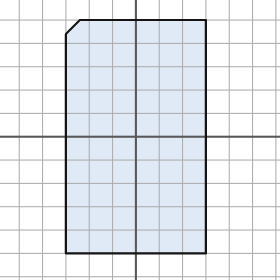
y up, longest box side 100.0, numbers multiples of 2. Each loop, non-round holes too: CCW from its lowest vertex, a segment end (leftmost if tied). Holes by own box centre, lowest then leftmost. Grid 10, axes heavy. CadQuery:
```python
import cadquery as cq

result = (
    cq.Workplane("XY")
    .moveTo(-30.0, -50.0)
    .lineTo(30.0, -50.0)
    .lineTo(30.0, 50.0)
    .lineTo(-24.0, 50.0)
    .lineTo(-30.0, 44.0)
    .close()
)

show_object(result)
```